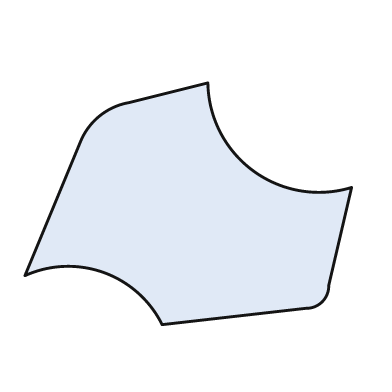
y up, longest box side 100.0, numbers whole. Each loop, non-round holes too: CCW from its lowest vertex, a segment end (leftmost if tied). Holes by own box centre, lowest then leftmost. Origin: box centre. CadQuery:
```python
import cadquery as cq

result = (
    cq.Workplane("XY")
    .moveTo(-8.0, -37.0)
    .lineTo(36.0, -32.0)
    .threePointArc((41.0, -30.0), (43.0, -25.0))
    .lineTo(50.0, 5.0)
    .threePointArc((20.0, 10.0), (6.0, 37.0))
    .lineTo(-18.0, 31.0)
    .threePointArc((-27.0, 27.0), (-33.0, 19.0))
    .lineTo(-50.0, -22.0)
    .threePointArc((-26.0, -21.0), (-8.0, -37.0))
    .close()
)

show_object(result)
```